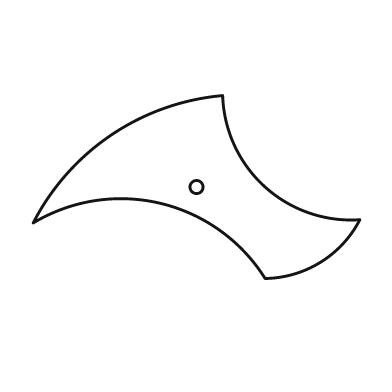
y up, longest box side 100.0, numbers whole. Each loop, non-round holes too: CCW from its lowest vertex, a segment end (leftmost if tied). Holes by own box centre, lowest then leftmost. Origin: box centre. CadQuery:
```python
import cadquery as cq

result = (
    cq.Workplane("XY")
    .moveTo(21.0, -28.0)
    .threePointArc((38.0, -23.0), (50.0, -10.0))
    .threePointArc((21.0, 0.0), (8.0, 28.0))
    .threePointArc((-26.0, 16.0), (-50.0, -11.0))
    .threePointArc((-11.0, -5.0), (21.0, -28.0))
    .close()
    .moveTo(0.0, 0.0)
    .circle(2.0)
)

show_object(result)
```